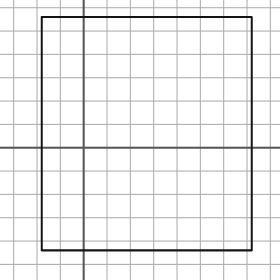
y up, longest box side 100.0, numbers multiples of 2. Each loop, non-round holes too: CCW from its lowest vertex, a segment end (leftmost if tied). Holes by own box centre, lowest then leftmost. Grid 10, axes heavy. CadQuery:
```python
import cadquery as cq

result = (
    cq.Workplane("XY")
    .moveTo(-18.0, -44.0)
    .lineTo(72.0, -44.0)
    .lineTo(72.0, 56.0)
    .lineTo(-18.0, 56.0)
    .close()
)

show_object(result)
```